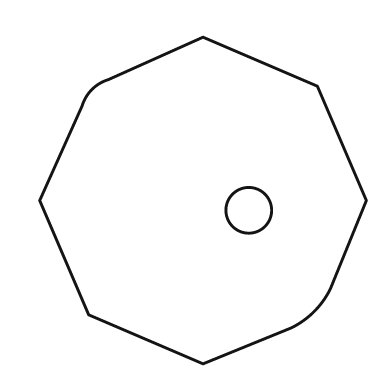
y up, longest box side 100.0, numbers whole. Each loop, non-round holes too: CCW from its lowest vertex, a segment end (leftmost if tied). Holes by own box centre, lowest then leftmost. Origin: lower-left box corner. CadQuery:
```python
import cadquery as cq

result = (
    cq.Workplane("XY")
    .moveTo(50.0, 0.0)
    .lineTo(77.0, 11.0)
    .threePointArc((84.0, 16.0), (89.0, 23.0))
    .lineTo(100.0, 50.0)
    .lineTo(85.0, 85.0)
    .lineTo(50.0, 100.0)
    .lineTo(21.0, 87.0)
    .threePointArc((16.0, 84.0), (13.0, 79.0))
    .lineTo(0.0, 50.0)
    .lineTo(15.0, 15.0)
    .close()
    .moveTo(64.0, 47.0)
    .circle(7.0)
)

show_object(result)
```